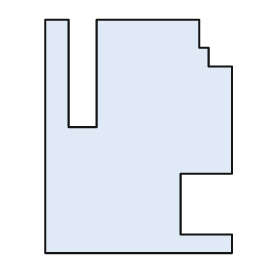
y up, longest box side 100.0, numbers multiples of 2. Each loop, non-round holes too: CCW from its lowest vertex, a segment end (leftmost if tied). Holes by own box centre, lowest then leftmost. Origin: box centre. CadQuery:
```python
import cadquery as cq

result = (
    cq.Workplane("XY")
    .moveTo(-40.0, -50.0)
    .lineTo(40.0, -50.0)
    .lineTo(40.0, -42.0)
    .lineTo(18.0, -42.0)
    .lineTo(18.0, -16.0)
    .lineTo(40.0, -16.0)
    .lineTo(40.0, 30.0)
    .lineTo(30.0, 30.0)
    .lineTo(30.0, 38.0)
    .lineTo(26.0, 38.0)
    .lineTo(26.0, 50.0)
    .lineTo(-18.0, 50.0)
    .lineTo(-18.0, 4.0)
    .lineTo(-30.0, 4.0)
    .lineTo(-30.0, 50.0)
    .lineTo(-40.0, 50.0)
    .close()
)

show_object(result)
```